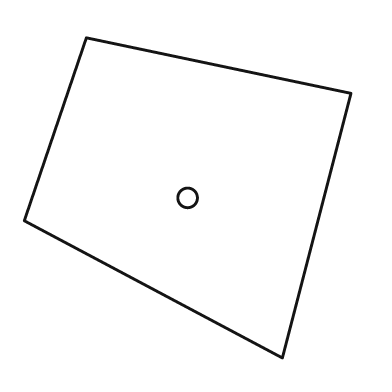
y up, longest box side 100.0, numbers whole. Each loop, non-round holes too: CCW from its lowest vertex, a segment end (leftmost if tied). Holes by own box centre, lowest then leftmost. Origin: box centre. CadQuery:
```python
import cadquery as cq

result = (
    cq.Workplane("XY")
    .moveTo(29.0, -49.0)
    .lineTo(50.0, 32.0)
    .lineTo(-31.0, 49.0)
    .lineTo(-50.0, -7.0)
    .close()
    .moveTo(0.0, 0.0)
    .circle(3.0)
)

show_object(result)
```